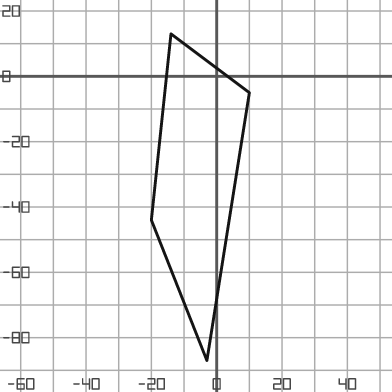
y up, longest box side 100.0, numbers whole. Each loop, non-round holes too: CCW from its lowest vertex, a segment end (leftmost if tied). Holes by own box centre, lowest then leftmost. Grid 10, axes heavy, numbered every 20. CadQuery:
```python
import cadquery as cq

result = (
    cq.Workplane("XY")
    .moveTo(-3.0, -87.0)
    .lineTo(10.0, -5.0)
    .lineTo(-14.0, 13.0)
    .lineTo(-20.0, -44.0)
    .close()
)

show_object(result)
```